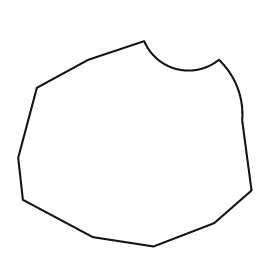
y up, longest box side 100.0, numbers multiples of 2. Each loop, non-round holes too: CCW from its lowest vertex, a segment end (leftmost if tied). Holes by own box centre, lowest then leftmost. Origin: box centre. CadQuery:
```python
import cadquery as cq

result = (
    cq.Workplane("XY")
    .moveTo(8.0, -44.0)
    .lineTo(34.0, -34.0)
    .lineTo(50.0, -20.0)
    .lineTo(46.0, 10.0)
    .threePointArc((44.0, 24.0), (36.0, 36.0))
    .threePointArc((18.0, 32.0), (4.0, 44.0))
    .lineTo(-20.0, 36.0)
    .lineTo(-42.0, 24.0)
    .lineTo(-50.0, -6.0)
    .lineTo(-48.0, -24.0)
    .lineTo(-18.0, -40.0)
    .close()
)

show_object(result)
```